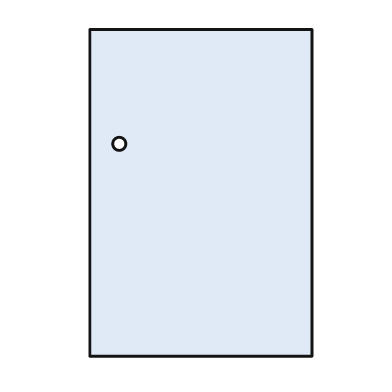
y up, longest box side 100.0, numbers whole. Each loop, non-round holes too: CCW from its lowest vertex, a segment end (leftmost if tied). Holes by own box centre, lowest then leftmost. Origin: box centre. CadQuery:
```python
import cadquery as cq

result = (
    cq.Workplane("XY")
    .moveTo(-34.0, -50.0)
    .lineTo(34.0, -50.0)
    .lineTo(34.0, 50.0)
    .lineTo(-34.0, 50.0)
    .close()
    .moveTo(-25.0, 15.0)
    .circle(2.0)
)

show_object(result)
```